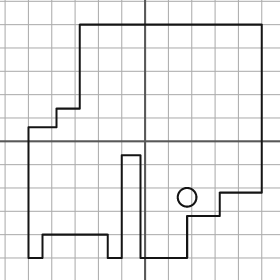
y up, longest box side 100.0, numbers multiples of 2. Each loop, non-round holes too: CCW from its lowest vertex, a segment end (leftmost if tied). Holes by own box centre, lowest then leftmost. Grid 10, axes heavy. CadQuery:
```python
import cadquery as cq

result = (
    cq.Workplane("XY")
    .moveTo(-50.0, -50.0)
    .lineTo(-44.0, -50.0)
    .lineTo(-44.0, -40.0)
    .lineTo(-16.0, -40.0)
    .lineTo(-16.0, -50.0)
    .lineTo(-10.0, -50.0)
    .lineTo(-10.0, -6.0)
    .lineTo(-2.0, -6.0)
    .lineTo(-2.0, -50.0)
    .lineTo(18.0, -50.0)
    .lineTo(18.0, -32.0)
    .lineTo(32.0, -32.0)
    .lineTo(32.0, -22.0)
    .lineTo(50.0, -22.0)
    .lineTo(50.0, 50.0)
    .lineTo(-28.0, 50.0)
    .lineTo(-28.0, 14.0)
    .lineTo(-38.0, 14.0)
    .lineTo(-38.0, 6.0)
    .lineTo(-50.0, 6.0)
    .close()
    .moveTo(18.0, -24.0)
    .circle(4.0)
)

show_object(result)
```